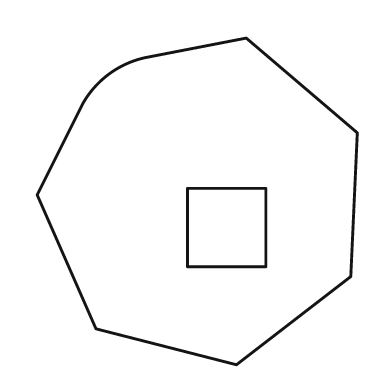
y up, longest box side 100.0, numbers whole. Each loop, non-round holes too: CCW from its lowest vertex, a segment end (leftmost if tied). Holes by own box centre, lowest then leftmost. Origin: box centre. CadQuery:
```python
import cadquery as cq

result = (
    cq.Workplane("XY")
    .moveTo(12.0, -50.0)
    .lineTo(47.0, -23.0)
    .lineTo(49.0, 21.0)
    .lineTo(15.0, 50.0)
    .lineTo(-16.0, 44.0)
    .threePointArc((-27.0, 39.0), (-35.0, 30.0))
    .lineTo(-49.0, 2.0)
    .lineTo(-31.0, -39.0)
    .close()
    .moveTo(-3.0, -20.0)
    .lineTo(21.0, -20.0)
    .lineTo(21.0, 4.0)
    .lineTo(-3.0, 4.0)
    .close()
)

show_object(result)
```